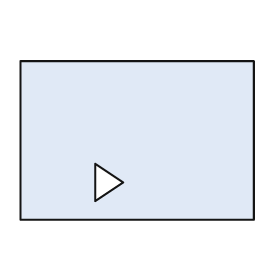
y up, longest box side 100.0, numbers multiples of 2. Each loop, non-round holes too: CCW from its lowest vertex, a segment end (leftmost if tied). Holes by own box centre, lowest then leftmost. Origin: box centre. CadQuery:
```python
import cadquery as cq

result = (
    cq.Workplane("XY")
    .moveTo(-50.0, -34.0)
    .lineTo(50.0, -34.0)
    .lineTo(50.0, 34.0)
    .lineTo(-50.0, 34.0)
    .close()
    .moveTo(-18.0, -26.0)
    .lineTo(-6.0, -18.0)
    .lineTo(-18.0, -10.0)
    .close()
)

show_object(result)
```